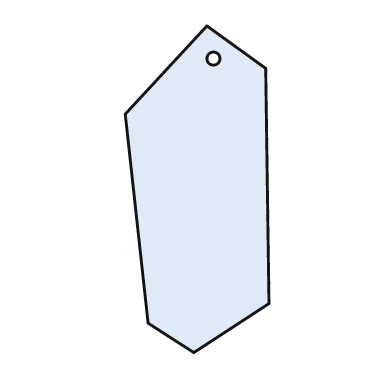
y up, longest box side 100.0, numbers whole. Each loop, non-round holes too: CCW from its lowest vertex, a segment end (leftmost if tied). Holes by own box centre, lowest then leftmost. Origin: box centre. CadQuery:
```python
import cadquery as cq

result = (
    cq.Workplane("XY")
    .moveTo(-1.0, -50.0)
    .lineTo(22.0, -35.0)
    .lineTo(21.0, 37.0)
    .lineTo(3.0, 50.0)
    .lineTo(-22.0, 23.0)
    .lineTo(-15.0, -41.0)
    .close()
    .moveTo(5.0, 40.0)
    .circle(2.0)
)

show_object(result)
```